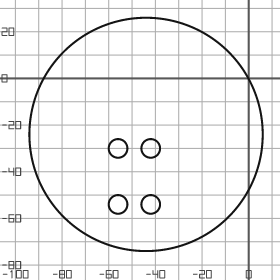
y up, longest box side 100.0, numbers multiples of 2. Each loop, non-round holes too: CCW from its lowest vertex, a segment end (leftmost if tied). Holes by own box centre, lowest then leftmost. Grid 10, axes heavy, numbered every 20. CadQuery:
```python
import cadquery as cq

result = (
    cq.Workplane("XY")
    .moveTo(-44.0, -24.0)
    .circle(50.0)
    .moveTo(-56.0, -54.0)
    .circle(4.0)
    .moveTo(-42.0, -54.0)
    .circle(4.0)
    .moveTo(-56.0, -30.0)
    .circle(4.0)
    .moveTo(-42.0, -30.0)
    .circle(4.0)
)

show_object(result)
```